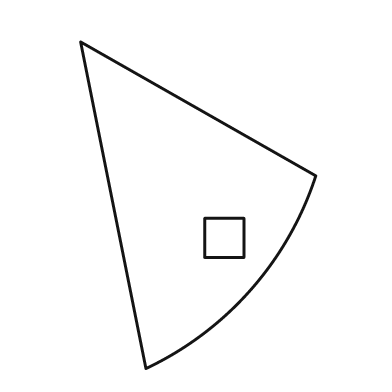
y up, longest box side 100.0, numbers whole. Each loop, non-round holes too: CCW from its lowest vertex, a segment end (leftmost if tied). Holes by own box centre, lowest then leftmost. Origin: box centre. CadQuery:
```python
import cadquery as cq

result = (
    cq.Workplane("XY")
    .moveTo(-16.0, -50.0)
    .threePointArc((16.0, -26.0), (36.0, 9.0))
    .lineTo(-36.0, 50.0)
    .close()
    .moveTo(2.0, -16.0)
    .lineTo(14.0, -16.0)
    .lineTo(14.0, -4.0)
    .lineTo(2.0, -4.0)
    .close()
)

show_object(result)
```